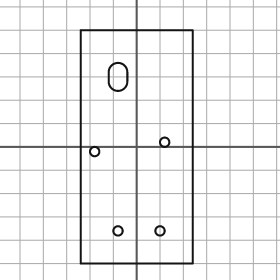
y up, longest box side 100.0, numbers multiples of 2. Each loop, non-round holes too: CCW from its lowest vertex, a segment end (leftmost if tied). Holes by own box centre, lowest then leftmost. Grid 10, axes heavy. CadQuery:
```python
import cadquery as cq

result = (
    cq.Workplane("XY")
    .moveTo(-24.0, -50.0)
    .lineTo(24.0, -50.0)
    .lineTo(24.0, 50.0)
    .lineTo(-24.0, 50.0)
    .close()
    .moveTo(-8.0, -36.0)
    .circle(2.0)
    .moveTo(10.0, -36.0)
    .circle(2.0)
    .moveTo(-18.0, -2.0)
    .circle(2.0)
    .moveTo(12.0, 2.0)
    .circle(2.0)
    .moveTo(-12.0, 28.0)
    .threePointArc((-8.0, 24.0), (-4.0, 28.0))
    .lineTo(-4.0, 32.0)
    .threePointArc((-8.0, 36.0), (-12.0, 32.0))
    .close()
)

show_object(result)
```